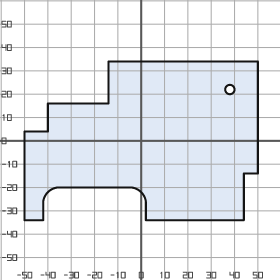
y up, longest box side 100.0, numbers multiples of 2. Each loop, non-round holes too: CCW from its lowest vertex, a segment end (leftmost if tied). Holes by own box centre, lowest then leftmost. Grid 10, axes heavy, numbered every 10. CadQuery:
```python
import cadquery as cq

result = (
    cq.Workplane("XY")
    .moveTo(-50.0, -34.0)
    .lineTo(-42.0, -34.0)
    .lineTo(-42.0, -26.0)
    .threePointArc((-40.0, -22.0), (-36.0, -20.0))
    .lineTo(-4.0, -20.0)
    .threePointArc((0.0, -22.0), (2.0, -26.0))
    .lineTo(2.0, -34.0)
    .lineTo(44.0, -34.0)
    .lineTo(44.0, -14.0)
    .lineTo(50.0, -14.0)
    .lineTo(50.0, 34.0)
    .lineTo(-14.0, 34.0)
    .lineTo(-14.0, 16.0)
    .lineTo(-40.0, 16.0)
    .lineTo(-40.0, 4.0)
    .lineTo(-50.0, 4.0)
    .close()
    .moveTo(38.0, 22.0)
    .circle(2.0)
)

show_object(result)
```